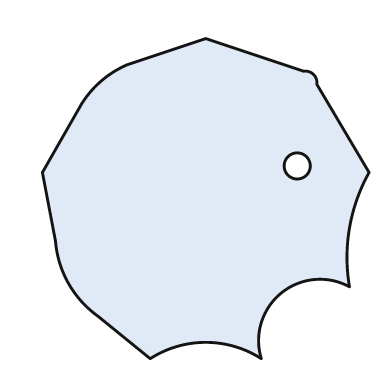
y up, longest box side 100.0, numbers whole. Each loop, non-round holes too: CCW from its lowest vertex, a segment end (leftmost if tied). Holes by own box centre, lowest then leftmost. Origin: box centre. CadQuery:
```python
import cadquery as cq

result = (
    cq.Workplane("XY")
    .moveTo(-17.0, -49.0)
    .threePointArc((0.0, -44.0), (17.0, -49.0))
    .threePointArc((23.0, -29.0), (44.0, -27.0))
    .threePointArc((44.0, -9.0), (50.0, 8.0))
    .lineTo(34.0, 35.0)
    .threePointArc((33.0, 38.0), (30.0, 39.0))
    .lineTo(0.0, 49.0)
    .lineTo(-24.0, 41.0)
    .threePointArc((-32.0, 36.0), (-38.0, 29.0))
    .lineTo(-50.0, 8.0)
    .lineTo(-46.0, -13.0)
    .threePointArc((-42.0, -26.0), (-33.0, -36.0))
    .close()
    .moveTo(28.0, 10.0)
    .circle(4.0)
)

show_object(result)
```